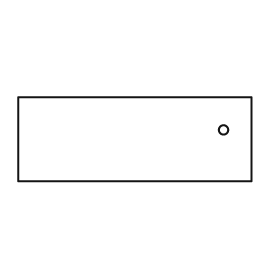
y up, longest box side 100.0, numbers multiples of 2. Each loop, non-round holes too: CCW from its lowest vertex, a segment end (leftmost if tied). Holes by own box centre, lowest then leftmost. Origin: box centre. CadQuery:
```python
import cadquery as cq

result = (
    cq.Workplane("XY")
    .moveTo(-50.0, -18.0)
    .lineTo(50.0, -18.0)
    .lineTo(50.0, 18.0)
    .lineTo(-50.0, 18.0)
    .close()
    .moveTo(38.0, 4.0)
    .circle(2.0)
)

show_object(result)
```